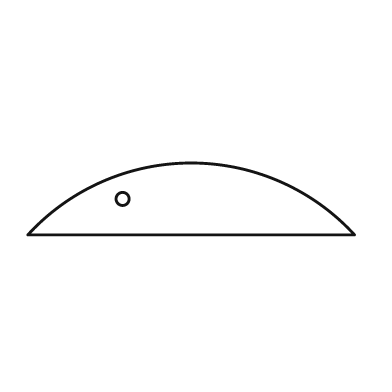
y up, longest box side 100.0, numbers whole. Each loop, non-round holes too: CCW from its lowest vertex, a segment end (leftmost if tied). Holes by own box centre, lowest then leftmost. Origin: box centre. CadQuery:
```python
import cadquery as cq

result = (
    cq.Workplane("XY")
    .moveTo(-50.0, -11.0)
    .lineTo(50.0, -11.0)
    .threePointArc((0.0, 11.0), (-50.0, -11.0))
    .close()
    .moveTo(-21.0, 0.0)
    .circle(2.0)
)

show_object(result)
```